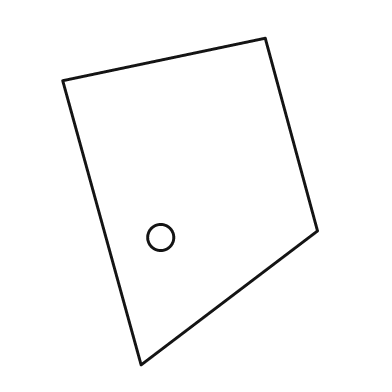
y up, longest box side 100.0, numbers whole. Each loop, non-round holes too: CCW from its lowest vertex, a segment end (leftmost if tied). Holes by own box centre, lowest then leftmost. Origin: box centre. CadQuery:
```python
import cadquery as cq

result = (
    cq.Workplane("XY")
    .moveTo(-15.0, -50.0)
    .lineTo(39.0, -9.0)
    .lineTo(23.0, 50.0)
    .lineTo(-39.0, 37.0)
    .close()
    .moveTo(-9.0, -11.0)
    .circle(4.0)
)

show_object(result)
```